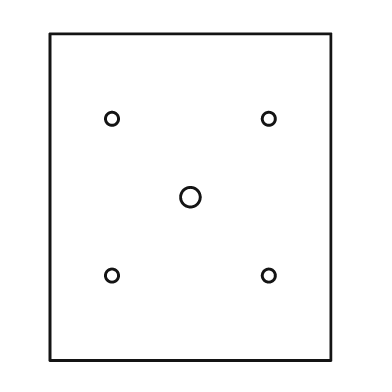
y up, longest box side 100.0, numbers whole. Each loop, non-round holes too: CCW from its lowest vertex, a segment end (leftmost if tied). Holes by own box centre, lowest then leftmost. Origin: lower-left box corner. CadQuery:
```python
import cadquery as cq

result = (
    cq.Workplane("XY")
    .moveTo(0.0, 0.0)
    .lineTo(86.0, 0.0)
    .lineTo(86.0, 100.0)
    .lineTo(0.0, 100.0)
    .close()
    .moveTo(19.0, 26.0)
    .circle(2.0)
    .moveTo(67.0, 26.0)
    .circle(2.0)
    .moveTo(43.0, 50.0)
    .circle(3.0)
    .moveTo(19.0, 74.0)
    .circle(2.0)
    .moveTo(67.0, 74.0)
    .circle(2.0)
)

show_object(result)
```